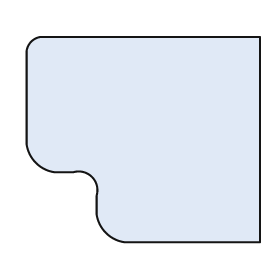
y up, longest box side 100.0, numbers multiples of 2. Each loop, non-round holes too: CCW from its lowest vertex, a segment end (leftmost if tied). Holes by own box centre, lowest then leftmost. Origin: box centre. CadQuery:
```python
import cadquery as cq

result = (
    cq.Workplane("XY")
    .moveTo(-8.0, -44.0)
    .lineTo(50.0, -44.0)
    .lineTo(50.0, 44.0)
    .lineTo(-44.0, 44.0)
    .threePointArc((-48.0, 42.0), (-50.0, 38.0))
    .lineTo(-50.0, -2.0)
    .threePointArc((-46.0, -10.0), (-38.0, -14.0))
    .lineTo(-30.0, -14.0)
    .threePointArc((-22.0, -16.0), (-20.0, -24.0))
    .lineTo(-20.0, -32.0)
    .threePointArc((-16.0, -40.0), (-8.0, -44.0))
    .close()
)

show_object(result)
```